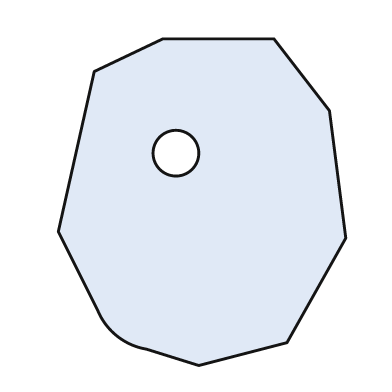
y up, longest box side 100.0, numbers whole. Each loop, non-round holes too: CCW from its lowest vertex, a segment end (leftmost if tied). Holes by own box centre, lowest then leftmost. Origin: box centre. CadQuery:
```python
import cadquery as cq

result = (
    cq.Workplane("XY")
    .moveTo(-1.0, -50.0)
    .lineTo(26.0, -43.0)
    .lineTo(44.0, -11.0)
    .lineTo(39.0, 28.0)
    .lineTo(22.0, 50.0)
    .lineTo(-12.0, 50.0)
    .lineTo(-33.0, 40.0)
    .lineTo(-44.0, -9.0)
    .lineTo(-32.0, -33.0)
    .threePointArc((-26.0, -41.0), (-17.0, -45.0))
    .close()
    .moveTo(-8.0, 15.0)
    .circle(7.0)
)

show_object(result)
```